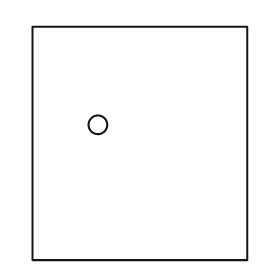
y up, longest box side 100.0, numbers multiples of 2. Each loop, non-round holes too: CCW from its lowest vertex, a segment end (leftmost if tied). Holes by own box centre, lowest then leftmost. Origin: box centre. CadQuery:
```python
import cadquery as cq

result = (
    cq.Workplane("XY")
    .moveTo(-46.0, -50.0)
    .lineTo(46.0, -50.0)
    .lineTo(46.0, 50.0)
    .lineTo(-46.0, 50.0)
    .close()
    .moveTo(-18.0, 8.0)
    .circle(4.0)
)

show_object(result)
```